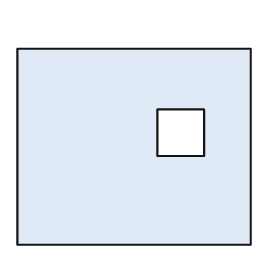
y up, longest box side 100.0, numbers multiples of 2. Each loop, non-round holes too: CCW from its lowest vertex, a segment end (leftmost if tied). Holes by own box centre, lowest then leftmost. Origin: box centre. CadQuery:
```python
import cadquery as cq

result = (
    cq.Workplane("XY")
    .moveTo(-50.0, -42.0)
    .lineTo(50.0, -42.0)
    .lineTo(50.0, 42.0)
    .lineTo(-50.0, 42.0)
    .close()
    .moveTo(10.0, -4.0)
    .lineTo(30.0, -4.0)
    .lineTo(30.0, 16.0)
    .lineTo(10.0, 16.0)
    .close()
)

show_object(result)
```